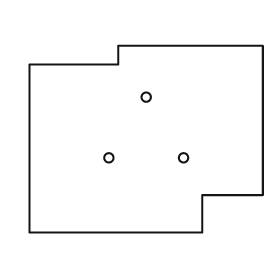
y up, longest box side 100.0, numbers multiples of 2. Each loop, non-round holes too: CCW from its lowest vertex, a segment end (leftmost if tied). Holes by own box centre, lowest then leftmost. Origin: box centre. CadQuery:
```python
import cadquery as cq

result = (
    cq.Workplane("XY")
    .moveTo(-50.0, -40.0)
    .lineTo(24.0, -40.0)
    .lineTo(24.0, -24.0)
    .lineTo(50.0, -24.0)
    .lineTo(50.0, 40.0)
    .lineTo(-12.0, 40.0)
    .lineTo(-12.0, 32.0)
    .lineTo(-50.0, 32.0)
    .close()
    .moveTo(-16.0, -8.0)
    .circle(2.0)
    .moveTo(16.0, -8.0)
    .circle(2.0)
    .moveTo(0.0, 18.0)
    .circle(2.0)
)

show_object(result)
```